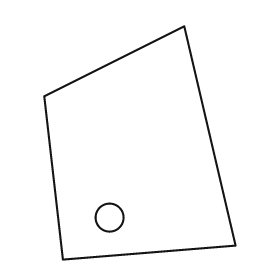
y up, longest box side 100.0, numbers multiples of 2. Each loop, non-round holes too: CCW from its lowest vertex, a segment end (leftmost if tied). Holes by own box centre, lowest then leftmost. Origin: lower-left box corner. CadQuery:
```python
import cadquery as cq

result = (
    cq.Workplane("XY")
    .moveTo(8.0, 0.0)
    .lineTo(82.0, 6.0)
    .lineTo(60.0, 100.0)
    .lineTo(0.0, 70.0)
    .close()
    .moveTo(28.0, 18.0)
    .circle(6.0)
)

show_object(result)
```